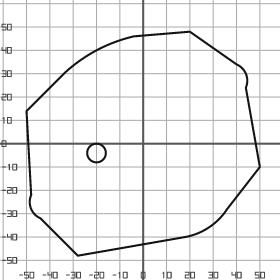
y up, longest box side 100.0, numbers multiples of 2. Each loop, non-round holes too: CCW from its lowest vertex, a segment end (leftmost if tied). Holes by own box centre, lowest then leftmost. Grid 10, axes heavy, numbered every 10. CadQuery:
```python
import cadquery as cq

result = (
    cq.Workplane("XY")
    .moveTo(-28.0, -48.0)
    .lineTo(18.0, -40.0)
    .threePointArc((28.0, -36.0), (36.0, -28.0))
    .lineTo(50.0, -10.0)
    .lineTo(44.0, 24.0)
    .threePointArc((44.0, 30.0), (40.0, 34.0))
    .lineTo(20.0, 48.0)
    .lineTo(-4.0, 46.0)
    .threePointArc((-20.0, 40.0), (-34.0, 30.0))
    .lineTo(-50.0, 14.0)
    .lineTo(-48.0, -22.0)
    .threePointArc((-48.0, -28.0), (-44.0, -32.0))
    .close()
    .moveTo(-20.0, -4.0)
    .circle(4.0)
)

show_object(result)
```